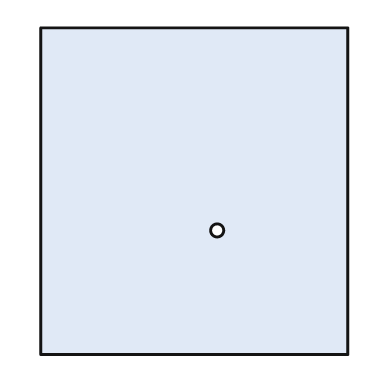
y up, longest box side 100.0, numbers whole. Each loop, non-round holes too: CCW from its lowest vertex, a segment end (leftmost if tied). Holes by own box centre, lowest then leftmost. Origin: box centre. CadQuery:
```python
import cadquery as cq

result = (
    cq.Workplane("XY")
    .moveTo(-47.0, -50.0)
    .lineTo(47.0, -50.0)
    .lineTo(47.0, 50.0)
    .lineTo(-47.0, 50.0)
    .close()
    .moveTo(7.0, -12.0)
    .circle(2.0)
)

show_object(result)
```